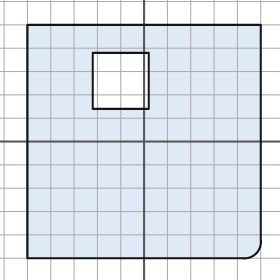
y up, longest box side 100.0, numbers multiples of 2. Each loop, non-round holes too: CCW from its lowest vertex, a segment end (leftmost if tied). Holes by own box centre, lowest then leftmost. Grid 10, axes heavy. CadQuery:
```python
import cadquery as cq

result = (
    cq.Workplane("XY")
    .moveTo(-50.0, -50.0)
    .lineTo(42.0, -50.0)
    .threePointArc((48.0, -48.0), (50.0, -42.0))
    .lineTo(50.0, 50.0)
    .lineTo(-50.0, 50.0)
    .close()
    .moveTo(-22.0, 14.0)
    .lineTo(2.0, 14.0)
    .lineTo(2.0, 38.0)
    .lineTo(-22.0, 38.0)
    .close()
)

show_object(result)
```